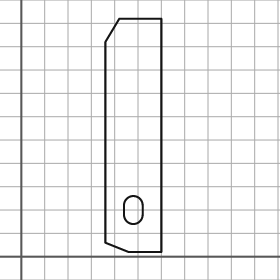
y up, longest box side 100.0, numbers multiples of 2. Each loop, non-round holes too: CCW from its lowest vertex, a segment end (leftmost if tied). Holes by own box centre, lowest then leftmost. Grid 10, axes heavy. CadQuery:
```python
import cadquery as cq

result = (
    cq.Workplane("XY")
    .moveTo(46.0, 2.0)
    .lineTo(60.0, 2.0)
    .lineTo(60.0, 102.0)
    .lineTo(42.0, 102.0)
    .lineTo(36.0, 92.0)
    .lineTo(36.0, 6.0)
    .close()
    .moveTo(44.0, 18.0)
    .threePointArc((48.0, 14.0), (52.0, 18.0))
    .lineTo(52.0, 22.0)
    .threePointArc((48.0, 26.0), (44.0, 22.0))
    .close()
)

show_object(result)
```